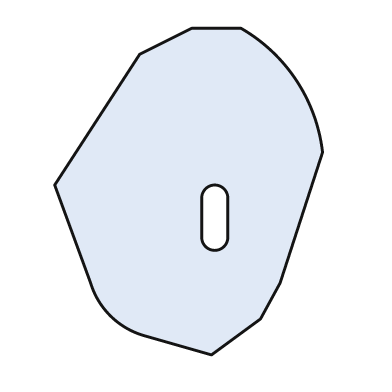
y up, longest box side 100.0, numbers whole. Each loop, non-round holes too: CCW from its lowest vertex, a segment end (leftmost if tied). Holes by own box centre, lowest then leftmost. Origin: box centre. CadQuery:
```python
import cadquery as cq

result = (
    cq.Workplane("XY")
    .moveTo(7.0, -50.0)
    .lineTo(22.0, -39.0)
    .lineTo(28.0, -28.0)
    .lineTo(41.0, 12.0)
    .threePointArc((33.0, 34.0), (16.0, 50.0))
    .lineTo(1.0, 50.0)
    .lineTo(-15.0, 42.0)
    .lineTo(-41.0, 2.0)
    .lineTo(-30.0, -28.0)
    .threePointArc((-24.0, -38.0), (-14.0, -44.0))
    .close()
    .moveTo(4.0, -14.0)
    .threePointArc((8.0, -18.0), (12.0, -14.0))
    .lineTo(12.0, -2.0)
    .threePointArc((8.0, 2.0), (4.0, -2.0))
    .close()
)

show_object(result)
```